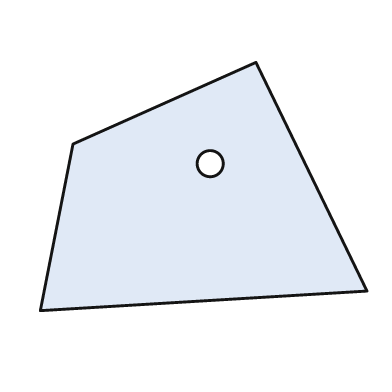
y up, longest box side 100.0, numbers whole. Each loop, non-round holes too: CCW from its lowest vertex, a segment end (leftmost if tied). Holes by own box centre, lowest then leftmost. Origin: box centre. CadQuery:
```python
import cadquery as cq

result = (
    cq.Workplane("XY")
    .moveTo(-50.0, -38.0)
    .lineTo(50.0, -32.0)
    .lineTo(16.0, 38.0)
    .lineTo(-40.0, 13.0)
    .close()
    .moveTo(2.0, 7.0)
    .circle(4.0)
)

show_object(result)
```